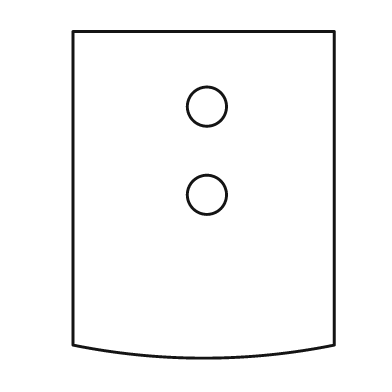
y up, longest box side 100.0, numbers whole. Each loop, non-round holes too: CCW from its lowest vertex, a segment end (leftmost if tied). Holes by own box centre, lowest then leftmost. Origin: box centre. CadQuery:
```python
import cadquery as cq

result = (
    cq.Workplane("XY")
    .moveTo(-40.0, -46.0)
    .threePointArc((0.0, -50.0), (40.0, -46.0))
    .lineTo(40.0, 50.0)
    .lineTo(-40.0, 50.0)
    .close()
    .moveTo(1.0, 0.0)
    .circle(6.0)
    .moveTo(1.0, 27.0)
    .circle(6.0)
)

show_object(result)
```